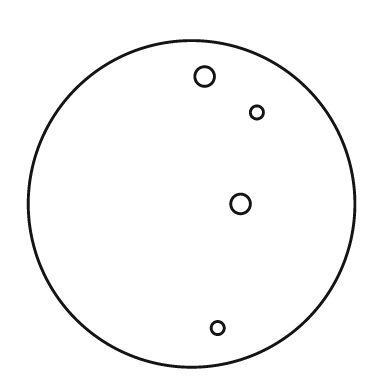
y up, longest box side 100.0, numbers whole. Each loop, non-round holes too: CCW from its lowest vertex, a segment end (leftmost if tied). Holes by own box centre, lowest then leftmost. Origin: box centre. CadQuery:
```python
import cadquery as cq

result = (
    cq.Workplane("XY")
    .moveTo(0.0, 0.0)
    .circle(50.0)
    .moveTo(8.0, -38.0)
    .circle(2.0)
    .moveTo(15.0, 0.0)
    .circle(3.0)
    .moveTo(20.0, 28.0)
    .circle(2.0)
    .moveTo(4.0, 39.0)
    .circle(3.0)
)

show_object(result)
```